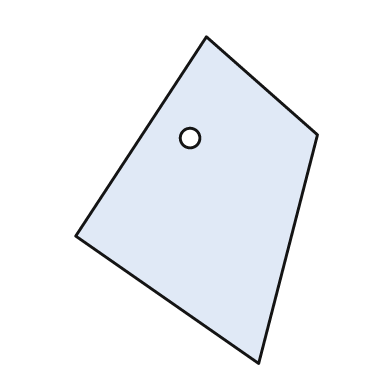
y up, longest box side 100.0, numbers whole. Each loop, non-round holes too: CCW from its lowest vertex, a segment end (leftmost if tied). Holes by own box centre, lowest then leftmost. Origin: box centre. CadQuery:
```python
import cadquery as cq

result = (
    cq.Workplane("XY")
    .moveTo(19.0, -50.0)
    .lineTo(37.0, 20.0)
    .lineTo(3.0, 50.0)
    .lineTo(-37.0, -11.0)
    .close()
    .moveTo(-2.0, 19.0)
    .circle(3.0)
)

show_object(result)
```